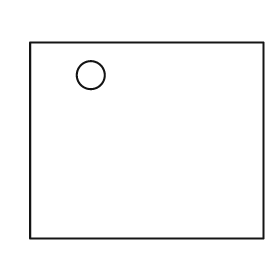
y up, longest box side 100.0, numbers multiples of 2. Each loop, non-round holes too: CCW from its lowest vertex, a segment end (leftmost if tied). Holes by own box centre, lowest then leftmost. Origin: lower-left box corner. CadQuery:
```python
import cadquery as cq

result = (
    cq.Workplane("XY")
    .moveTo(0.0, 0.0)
    .lineTo(100.0, 0.0)
    .lineTo(100.0, 84.0)
    .lineTo(0.0, 84.0)
    .close()
    .moveTo(26.0, 70.0)
    .circle(6.0)
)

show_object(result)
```